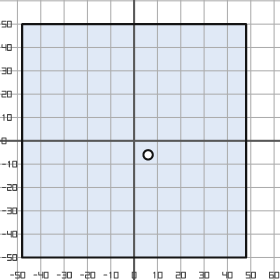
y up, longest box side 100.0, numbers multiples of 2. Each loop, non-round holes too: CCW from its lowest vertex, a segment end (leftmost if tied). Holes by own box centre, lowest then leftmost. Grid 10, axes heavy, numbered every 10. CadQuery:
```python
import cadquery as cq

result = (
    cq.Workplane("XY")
    .moveTo(-48.0, -50.0)
    .lineTo(48.0, -50.0)
    .lineTo(48.0, 50.0)
    .lineTo(-48.0, 50.0)
    .close()
    .moveTo(6.0, -6.0)
    .circle(2.0)
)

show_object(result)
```